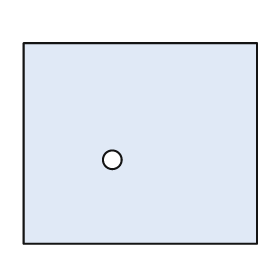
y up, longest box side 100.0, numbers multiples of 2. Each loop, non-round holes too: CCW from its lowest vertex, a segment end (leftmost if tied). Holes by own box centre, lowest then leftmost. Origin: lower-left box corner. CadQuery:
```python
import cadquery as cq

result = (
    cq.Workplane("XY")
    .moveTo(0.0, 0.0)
    .lineTo(100.0, 0.0)
    .lineTo(100.0, 86.0)
    .lineTo(0.0, 86.0)
    .close()
    .moveTo(38.0, 36.0)
    .circle(4.0)
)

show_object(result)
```